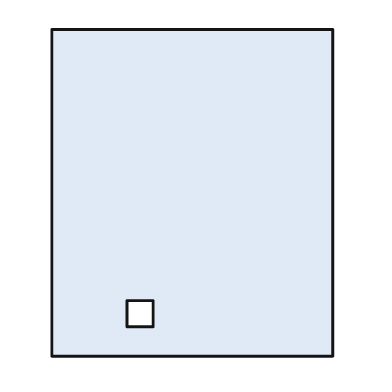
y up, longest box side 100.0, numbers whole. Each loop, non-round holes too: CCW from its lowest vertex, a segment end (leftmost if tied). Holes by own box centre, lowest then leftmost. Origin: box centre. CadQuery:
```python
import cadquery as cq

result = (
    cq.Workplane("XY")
    .moveTo(-43.0, -50.0)
    .lineTo(43.0, -50.0)
    .lineTo(43.0, 50.0)
    .lineTo(-43.0, 50.0)
    .close()
    .moveTo(-20.0, -41.0)
    .lineTo(-12.0, -41.0)
    .lineTo(-12.0, -33.0)
    .lineTo(-20.0, -33.0)
    .close()
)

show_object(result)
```